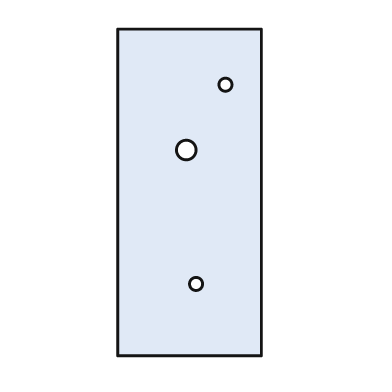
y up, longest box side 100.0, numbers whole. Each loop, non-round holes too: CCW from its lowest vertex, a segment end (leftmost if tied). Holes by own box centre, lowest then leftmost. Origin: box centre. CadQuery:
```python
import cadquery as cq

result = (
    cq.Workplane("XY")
    .moveTo(-22.0, -50.0)
    .lineTo(22.0, -50.0)
    .lineTo(22.0, 50.0)
    .lineTo(-22.0, 50.0)
    .close()
    .moveTo(2.0, -28.0)
    .circle(2.0)
    .moveTo(-1.0, 13.0)
    .circle(3.0)
    .moveTo(11.0, 33.0)
    .circle(2.0)
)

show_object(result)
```